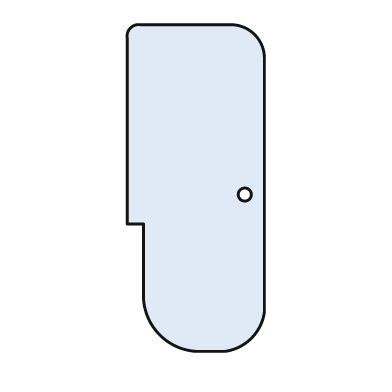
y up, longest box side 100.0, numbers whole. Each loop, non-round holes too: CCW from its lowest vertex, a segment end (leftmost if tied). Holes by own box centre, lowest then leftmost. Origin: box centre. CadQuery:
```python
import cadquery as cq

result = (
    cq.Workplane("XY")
    .moveTo(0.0, -50.0)
    .lineTo(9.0, -50.0)
    .threePointArc((17.0, -46.0), (21.0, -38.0))
    .lineTo(21.0, 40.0)
    .threePointArc((18.0, 47.0), (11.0, 50.0))
    .lineTo(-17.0, 50.0)
    .threePointArc((-20.0, 49.0), (-21.0, 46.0))
    .lineTo(-21.0, -11.0)
    .lineTo(-16.0, -11.0)
    .lineTo(-16.0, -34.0)
    .threePointArc((-11.0, -45.0), (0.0, -50.0))
    .close()
    .moveTo(15.0, -2.0)
    .circle(2.0)
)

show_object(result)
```